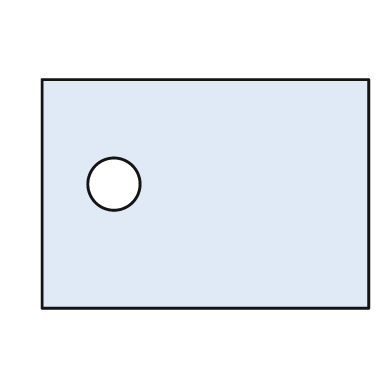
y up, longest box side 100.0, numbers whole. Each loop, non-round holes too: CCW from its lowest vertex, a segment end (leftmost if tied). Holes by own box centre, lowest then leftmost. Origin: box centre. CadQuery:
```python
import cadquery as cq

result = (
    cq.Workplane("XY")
    .moveTo(-50.0, -35.0)
    .lineTo(50.0, -35.0)
    .lineTo(50.0, 35.0)
    .lineTo(-50.0, 35.0)
    .close()
    .moveTo(-28.0, 3.0)
    .circle(8.0)
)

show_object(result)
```